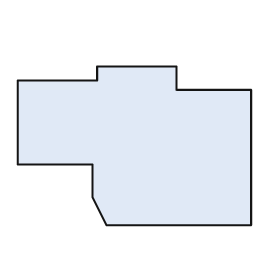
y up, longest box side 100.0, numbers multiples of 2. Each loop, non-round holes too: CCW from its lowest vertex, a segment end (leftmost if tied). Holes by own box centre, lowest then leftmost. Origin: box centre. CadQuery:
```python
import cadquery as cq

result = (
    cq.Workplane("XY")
    .moveTo(-12.0, -34.0)
    .lineTo(50.0, -34.0)
    .lineTo(50.0, 24.0)
    .lineTo(18.0, 24.0)
    .lineTo(18.0, 34.0)
    .lineTo(-16.0, 34.0)
    .lineTo(-16.0, 28.0)
    .lineTo(-50.0, 28.0)
    .lineTo(-50.0, -8.0)
    .lineTo(-18.0, -8.0)
    .lineTo(-18.0, -22.0)
    .close()
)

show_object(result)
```